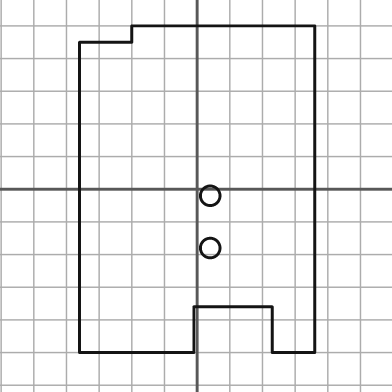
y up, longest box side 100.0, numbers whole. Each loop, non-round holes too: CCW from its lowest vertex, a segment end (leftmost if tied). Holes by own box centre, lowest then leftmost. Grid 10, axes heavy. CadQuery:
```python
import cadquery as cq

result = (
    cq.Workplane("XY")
    .moveTo(-36.0, -50.0)
    .lineTo(-1.0, -50.0)
    .lineTo(-1.0, -36.0)
    .lineTo(23.0, -36.0)
    .lineTo(23.0, -50.0)
    .lineTo(36.0, -50.0)
    .lineTo(36.0, 50.0)
    .lineTo(-20.0, 50.0)
    .lineTo(-20.0, 45.0)
    .lineTo(-36.0, 45.0)
    .close()
    .moveTo(4.0, -18.0)
    .circle(3.0)
    .moveTo(4.0, -2.0)
    .circle(3.0)
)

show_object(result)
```